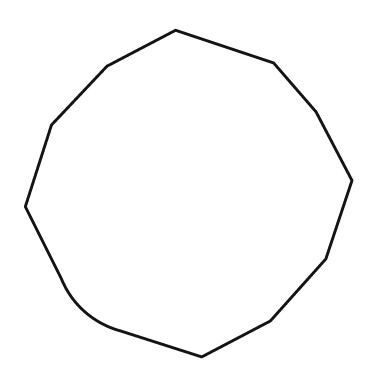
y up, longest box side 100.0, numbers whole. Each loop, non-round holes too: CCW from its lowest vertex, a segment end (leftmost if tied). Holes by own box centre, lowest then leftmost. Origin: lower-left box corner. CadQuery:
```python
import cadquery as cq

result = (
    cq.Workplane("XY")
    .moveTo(54.0, 0.0)
    .lineTo(75.0, 11.0)
    .lineTo(92.0, 30.0)
    .lineTo(100.0, 54.0)
    .lineTo(89.0, 75.0)
    .lineTo(76.0, 90.0)
    .lineTo(46.0, 100.0)
    .lineTo(25.0, 89.0)
    .lineTo(8.0, 71.0)
    .lineTo(0.0, 46.0)
    .lineTo(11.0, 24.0)
    .threePointArc((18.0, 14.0), (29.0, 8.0))
    .close()
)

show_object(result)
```